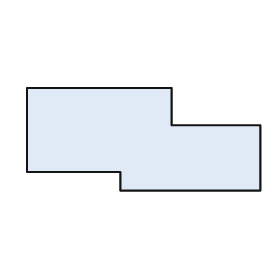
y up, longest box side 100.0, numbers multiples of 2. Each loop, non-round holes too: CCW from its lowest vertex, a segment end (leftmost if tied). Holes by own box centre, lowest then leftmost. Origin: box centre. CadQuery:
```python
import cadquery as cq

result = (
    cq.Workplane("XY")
    .moveTo(-10.0, -22.0)
    .lineTo(50.0, -22.0)
    .lineTo(50.0, 6.0)
    .lineTo(12.0, 6.0)
    .lineTo(12.0, 22.0)
    .lineTo(-50.0, 22.0)
    .lineTo(-50.0, -14.0)
    .lineTo(-10.0, -14.0)
    .close()
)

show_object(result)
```